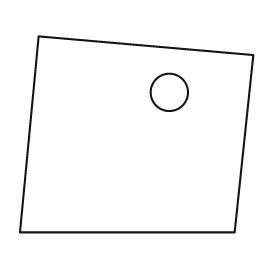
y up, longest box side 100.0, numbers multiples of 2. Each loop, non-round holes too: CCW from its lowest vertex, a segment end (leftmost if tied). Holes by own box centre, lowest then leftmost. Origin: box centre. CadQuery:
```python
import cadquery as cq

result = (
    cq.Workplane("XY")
    .moveTo(-50.0, -42.0)
    .lineTo(42.0, -42.0)
    .lineTo(50.0, 34.0)
    .lineTo(-42.0, 42.0)
    .close()
    .moveTo(14.0, 18.0)
    .circle(8.0)
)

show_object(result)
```